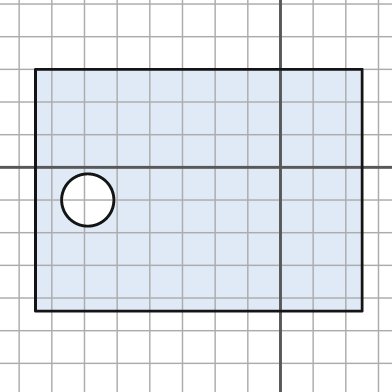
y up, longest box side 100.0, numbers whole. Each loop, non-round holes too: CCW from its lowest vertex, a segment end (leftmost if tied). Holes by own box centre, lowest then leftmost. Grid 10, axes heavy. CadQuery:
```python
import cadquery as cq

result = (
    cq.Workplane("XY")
    .moveTo(-75.0, -44.0)
    .lineTo(25.0, -44.0)
    .lineTo(25.0, 30.0)
    .lineTo(-75.0, 30.0)
    .close()
    .moveTo(-59.0, -10.0)
    .circle(8.0)
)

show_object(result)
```